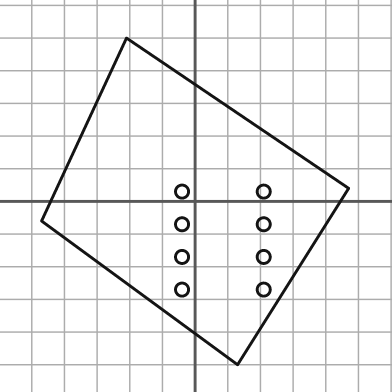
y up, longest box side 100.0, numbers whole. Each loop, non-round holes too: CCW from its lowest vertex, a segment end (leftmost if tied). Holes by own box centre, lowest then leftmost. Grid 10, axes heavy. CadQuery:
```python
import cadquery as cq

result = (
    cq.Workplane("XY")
    .moveTo(13.0, -50.0)
    .lineTo(47.0, 4.0)
    .lineTo(-21.0, 50.0)
    .lineTo(-47.0, -6.0)
    .close()
    .moveTo(-4.0, -27.0)
    .circle(2.0)
    .moveTo(21.0, -27.0)
    .circle(2.0)
    .moveTo(-4.0, -17.0)
    .circle(2.0)
    .moveTo(21.0, -17.0)
    .circle(2.0)
    .moveTo(-4.0, -7.0)
    .circle(2.0)
    .moveTo(21.0, -7.0)
    .circle(2.0)
    .moveTo(-4.0, 3.0)
    .circle(2.0)
    .moveTo(21.0, 3.0)
    .circle(2.0)
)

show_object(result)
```